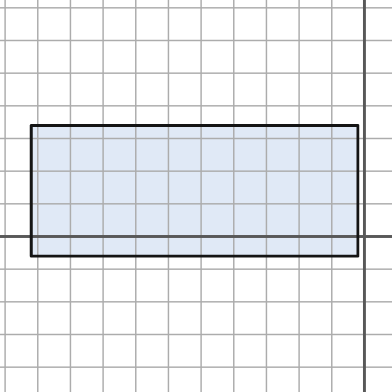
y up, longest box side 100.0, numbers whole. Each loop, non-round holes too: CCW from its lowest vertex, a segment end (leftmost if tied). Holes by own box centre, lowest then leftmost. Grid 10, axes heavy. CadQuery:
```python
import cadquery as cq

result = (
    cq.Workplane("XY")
    .moveTo(-102.0, -6.0)
    .lineTo(-2.0, -6.0)
    .lineTo(-2.0, 34.0)
    .lineTo(-102.0, 34.0)
    .close()
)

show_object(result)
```